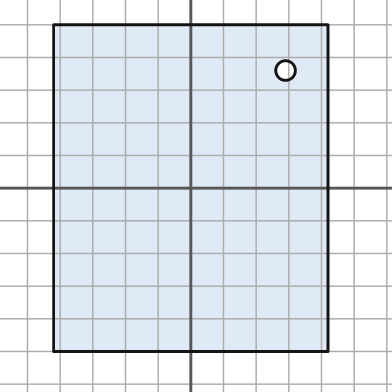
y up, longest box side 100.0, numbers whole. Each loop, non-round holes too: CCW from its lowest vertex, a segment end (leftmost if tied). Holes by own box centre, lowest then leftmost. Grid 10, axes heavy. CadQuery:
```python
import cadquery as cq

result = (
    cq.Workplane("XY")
    .moveTo(-42.0, -50.0)
    .lineTo(42.0, -50.0)
    .lineTo(42.0, 50.0)
    .lineTo(-42.0, 50.0)
    .close()
    .moveTo(29.0, 36.0)
    .circle(3.0)
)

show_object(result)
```